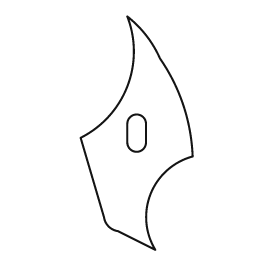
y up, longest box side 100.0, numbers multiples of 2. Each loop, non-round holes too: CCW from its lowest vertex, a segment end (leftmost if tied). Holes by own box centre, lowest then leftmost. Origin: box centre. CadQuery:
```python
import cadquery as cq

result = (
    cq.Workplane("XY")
    .moveTo(8.0, -50.0)
    .threePointArc((6.0, -26.0), (24.0, -10.0))
    .threePointArc((20.0, 12.0), (10.0, 32.0))
    .threePointArc((4.0, 42.0), (-4.0, 50.0))
    .threePointArc((-4.0, 20.0), (-24.0, -2.0))
    .lineTo(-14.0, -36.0)
    .threePointArc((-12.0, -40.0), (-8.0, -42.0))
    .close()
    .moveTo(-4.0, -4.0)
    .threePointArc((0.0, -8.0), (4.0, -4.0))
    .lineTo(4.0, 4.0)
    .threePointArc((0.0, 8.0), (-4.0, 4.0))
    .close()
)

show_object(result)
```